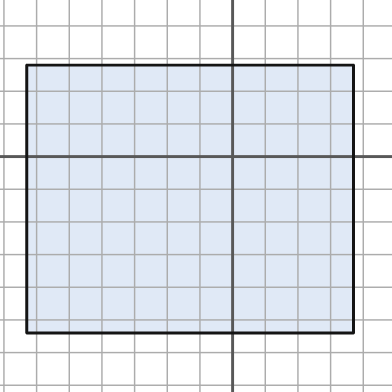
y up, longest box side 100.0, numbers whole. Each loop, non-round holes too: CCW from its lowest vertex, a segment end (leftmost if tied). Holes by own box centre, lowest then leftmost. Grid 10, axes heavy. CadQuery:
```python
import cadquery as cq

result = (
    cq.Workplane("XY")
    .moveTo(-63.0, -54.0)
    .lineTo(37.0, -54.0)
    .lineTo(37.0, 28.0)
    .lineTo(-63.0, 28.0)
    .close()
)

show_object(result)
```